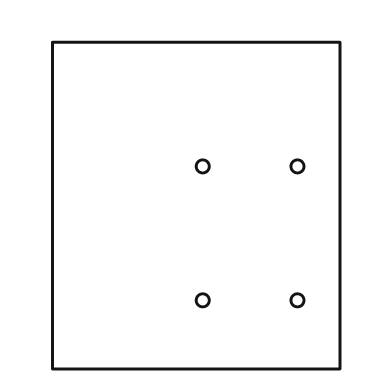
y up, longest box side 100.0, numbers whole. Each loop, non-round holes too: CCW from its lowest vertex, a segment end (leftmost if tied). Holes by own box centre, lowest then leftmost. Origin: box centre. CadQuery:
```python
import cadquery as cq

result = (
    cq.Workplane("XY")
    .moveTo(-44.0, -50.0)
    .lineTo(44.0, -50.0)
    .lineTo(44.0, 50.0)
    .lineTo(-44.0, 50.0)
    .close()
    .moveTo(2.0, -29.0)
    .circle(2.0)
    .moveTo(31.0, -29.0)
    .circle(2.0)
    .moveTo(2.0, 12.0)
    .circle(2.0)
    .moveTo(31.0, 12.0)
    .circle(2.0)
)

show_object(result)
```